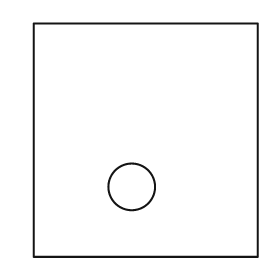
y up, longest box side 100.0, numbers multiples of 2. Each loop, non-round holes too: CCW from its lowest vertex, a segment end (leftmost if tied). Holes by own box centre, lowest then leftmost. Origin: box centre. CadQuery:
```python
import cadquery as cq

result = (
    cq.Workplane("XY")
    .moveTo(-48.0, -50.0)
    .lineTo(48.0, -50.0)
    .lineTo(48.0, 50.0)
    .lineTo(-48.0, 50.0)
    .close()
    .moveTo(-6.0, -20.0)
    .circle(10.0)
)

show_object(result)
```